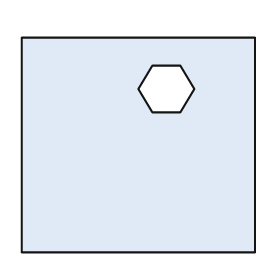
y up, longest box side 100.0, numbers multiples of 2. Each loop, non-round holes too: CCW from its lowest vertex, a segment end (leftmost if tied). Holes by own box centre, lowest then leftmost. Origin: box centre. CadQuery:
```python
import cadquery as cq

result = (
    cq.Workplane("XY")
    .moveTo(-50.0, -46.0)
    .lineTo(50.0, -46.0)
    .lineTo(50.0, 46.0)
    .lineTo(-50.0, 46.0)
    .close()
    .moveTo(6.0, 14.0)
    .lineTo(18.0, 14.0)
    .lineTo(24.0, 24.0)
    .lineTo(18.0, 34.0)
    .lineTo(6.0, 34.0)
    .lineTo(0.0, 24.0)
    .close()
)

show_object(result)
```